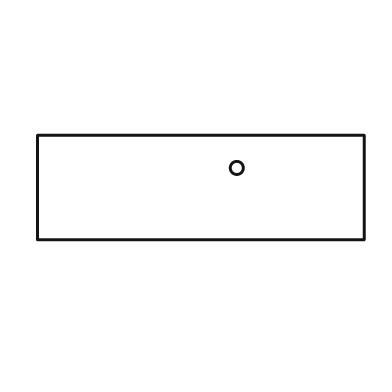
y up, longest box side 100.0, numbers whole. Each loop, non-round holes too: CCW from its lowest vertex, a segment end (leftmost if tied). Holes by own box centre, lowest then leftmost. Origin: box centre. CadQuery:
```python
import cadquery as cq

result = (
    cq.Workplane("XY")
    .moveTo(-50.0, -16.0)
    .lineTo(50.0, -16.0)
    .lineTo(50.0, 16.0)
    .lineTo(-50.0, 16.0)
    .close()
    .moveTo(11.0, 6.0)
    .circle(2.0)
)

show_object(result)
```